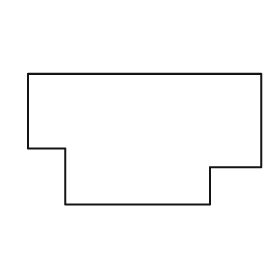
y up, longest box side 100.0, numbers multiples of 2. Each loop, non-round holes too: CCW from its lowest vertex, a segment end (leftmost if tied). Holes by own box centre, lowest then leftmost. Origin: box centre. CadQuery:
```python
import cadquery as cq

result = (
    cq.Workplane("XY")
    .moveTo(-34.0, -28.0)
    .lineTo(28.0, -28.0)
    .lineTo(28.0, -12.0)
    .lineTo(50.0, -12.0)
    .lineTo(50.0, 28.0)
    .lineTo(-50.0, 28.0)
    .lineTo(-50.0, -4.0)
    .lineTo(-34.0, -4.0)
    .close()
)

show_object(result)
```